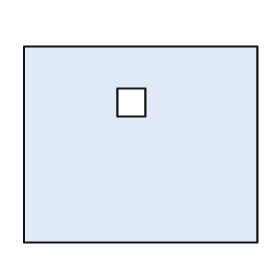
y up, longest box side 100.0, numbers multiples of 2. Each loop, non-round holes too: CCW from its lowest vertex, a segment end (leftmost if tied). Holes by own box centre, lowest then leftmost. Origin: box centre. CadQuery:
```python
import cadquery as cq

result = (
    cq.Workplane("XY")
    .moveTo(-50.0, -42.0)
    .lineTo(50.0, -42.0)
    .lineTo(50.0, 42.0)
    .lineTo(-50.0, 42.0)
    .close()
    .moveTo(-10.0, 12.0)
    .lineTo(2.0, 12.0)
    .lineTo(2.0, 24.0)
    .lineTo(-10.0, 24.0)
    .close()
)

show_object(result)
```